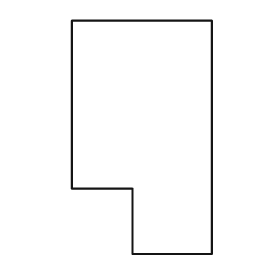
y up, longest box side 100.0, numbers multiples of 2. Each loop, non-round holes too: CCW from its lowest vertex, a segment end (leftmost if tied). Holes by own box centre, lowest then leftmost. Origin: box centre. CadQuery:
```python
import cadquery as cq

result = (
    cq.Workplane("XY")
    .moveTo(-4.0, -50.0)
    .lineTo(30.0, -50.0)
    .lineTo(30.0, 50.0)
    .lineTo(-30.0, 50.0)
    .lineTo(-30.0, -22.0)
    .lineTo(-4.0, -22.0)
    .close()
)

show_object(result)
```